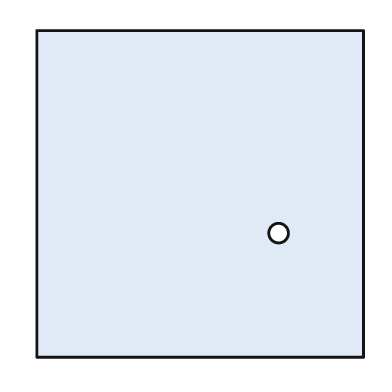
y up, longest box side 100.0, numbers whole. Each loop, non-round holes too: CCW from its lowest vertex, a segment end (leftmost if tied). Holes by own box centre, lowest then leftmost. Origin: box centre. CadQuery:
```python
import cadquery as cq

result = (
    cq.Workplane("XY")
    .moveTo(-50.0, -50.0)
    .lineTo(50.0, -50.0)
    .lineTo(50.0, 50.0)
    .lineTo(-50.0, 50.0)
    .close()
    .moveTo(24.0, -12.0)
    .circle(3.0)
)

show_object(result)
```